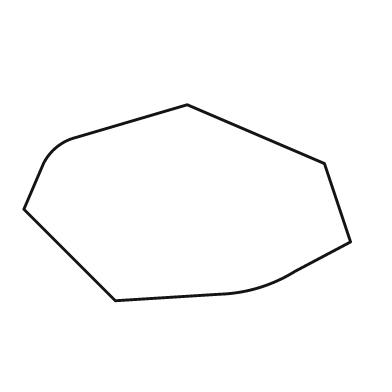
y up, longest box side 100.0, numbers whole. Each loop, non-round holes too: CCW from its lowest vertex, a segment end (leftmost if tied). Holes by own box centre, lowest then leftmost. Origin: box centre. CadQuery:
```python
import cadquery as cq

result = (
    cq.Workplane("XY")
    .moveTo(-22.0, -30.0)
    .lineTo(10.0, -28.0)
    .threePointArc((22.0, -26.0), (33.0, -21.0))
    .lineTo(50.0, -12.0)
    .lineTo(42.0, 12.0)
    .lineTo(0.0, 30.0)
    .lineTo(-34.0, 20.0)
    .threePointArc((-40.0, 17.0), (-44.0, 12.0))
    .lineTo(-50.0, -2.0)
    .close()
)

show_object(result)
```